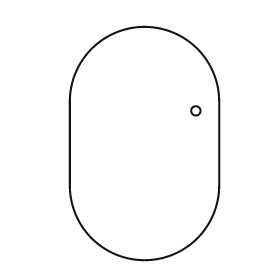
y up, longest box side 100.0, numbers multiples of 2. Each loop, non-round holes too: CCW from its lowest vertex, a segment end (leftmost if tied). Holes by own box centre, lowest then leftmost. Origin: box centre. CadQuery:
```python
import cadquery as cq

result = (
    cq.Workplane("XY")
    .moveTo(-32.0, -18.0)
    .threePointArc((0.0, -50.0), (32.0, -18.0))
    .lineTo(32.0, 18.0)
    .threePointArc((0.0, 50.0), (-32.0, 18.0))
    .close()
    .moveTo(22.0, 14.0)
    .circle(2.0)
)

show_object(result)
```